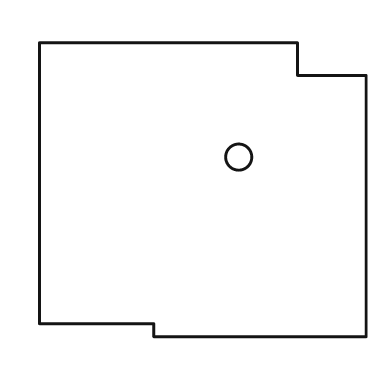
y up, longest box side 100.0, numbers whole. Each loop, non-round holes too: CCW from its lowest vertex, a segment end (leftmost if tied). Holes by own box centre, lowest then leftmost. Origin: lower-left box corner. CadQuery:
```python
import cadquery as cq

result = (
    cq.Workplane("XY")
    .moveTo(35.0, 0.0)
    .lineTo(100.0, 0.0)
    .lineTo(100.0, 80.0)
    .lineTo(79.0, 80.0)
    .lineTo(79.0, 90.0)
    .lineTo(0.0, 90.0)
    .lineTo(0.0, 4.0)
    .lineTo(35.0, 4.0)
    .close()
    .moveTo(61.0, 55.0)
    .circle(4.0)
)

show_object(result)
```